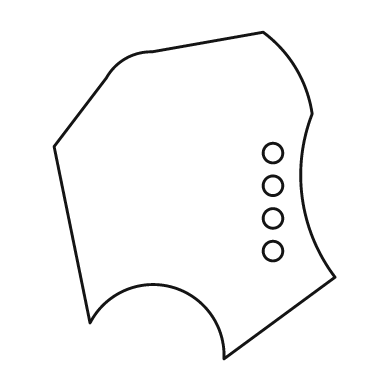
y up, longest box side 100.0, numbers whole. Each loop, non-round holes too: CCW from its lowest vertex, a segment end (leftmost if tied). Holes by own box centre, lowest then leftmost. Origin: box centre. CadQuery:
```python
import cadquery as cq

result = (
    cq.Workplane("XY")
    .moveTo(9.0, -50.0)
    .lineTo(43.0, -25.0)
    .threePointArc((33.0, -1.0), (36.0, 25.0))
    .threePointArc((31.0, 39.0), (21.0, 50.0))
    .lineTo(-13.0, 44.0)
    .threePointArc((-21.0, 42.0), (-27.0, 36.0))
    .lineTo(-43.0, 15.0)
    .lineTo(-32.0, -39.0)
    .threePointArc((-7.0, -28.0), (9.0, -50.0))
    .close()
    .moveTo(24.0, -17.0)
    .circle(3.0)
    .moveTo(24.0, -7.0)
    .circle(3.0)
    .moveTo(24.0, 3.0)
    .circle(3.0)
    .moveTo(24.0, 13.0)
    .circle(3.0)
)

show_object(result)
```